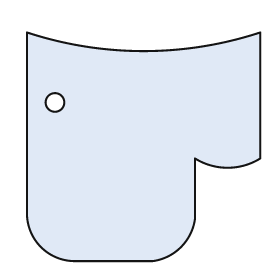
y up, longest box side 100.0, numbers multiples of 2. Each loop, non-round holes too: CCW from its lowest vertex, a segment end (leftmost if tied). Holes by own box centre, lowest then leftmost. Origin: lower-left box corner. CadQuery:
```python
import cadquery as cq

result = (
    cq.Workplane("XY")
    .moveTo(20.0, 0.0)
    .lineTo(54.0, 0.0)
    .threePointArc((66.0, 6.0), (72.0, 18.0))
    .lineTo(72.0, 44.0)
    .threePointArc((86.0, 40.0), (100.0, 44.0))
    .lineTo(100.0, 98.0)
    .threePointArc((50.0, 90.0), (0.0, 98.0))
    .lineTo(0.0, 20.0)
    .threePointArc((6.0, 6.0), (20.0, 0.0))
    .close()
    .moveTo(12.0, 68.0)
    .circle(4.0)
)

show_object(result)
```